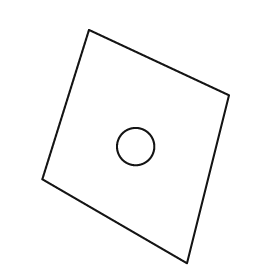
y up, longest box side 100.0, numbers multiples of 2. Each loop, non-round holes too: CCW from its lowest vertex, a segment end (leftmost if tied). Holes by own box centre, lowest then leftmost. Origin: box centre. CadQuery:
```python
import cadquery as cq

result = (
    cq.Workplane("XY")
    .moveTo(22.0, -50.0)
    .lineTo(40.0, 22.0)
    .lineTo(-20.0, 50.0)
    .lineTo(-40.0, -14.0)
    .close()
    .moveTo(0.0, 0.0)
    .circle(8.0)
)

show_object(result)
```